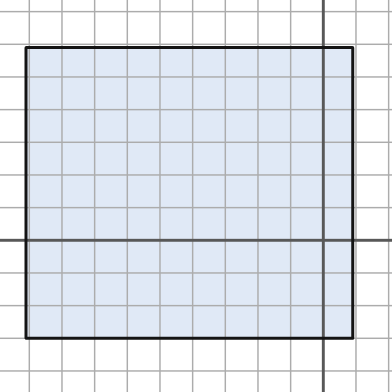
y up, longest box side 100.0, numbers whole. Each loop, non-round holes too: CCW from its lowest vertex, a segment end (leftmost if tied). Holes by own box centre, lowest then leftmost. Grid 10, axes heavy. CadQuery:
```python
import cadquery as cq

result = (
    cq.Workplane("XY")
    .moveTo(-91.0, -30.0)
    .lineTo(9.0, -30.0)
    .lineTo(9.0, 59.0)
    .lineTo(-91.0, 59.0)
    .close()
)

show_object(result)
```